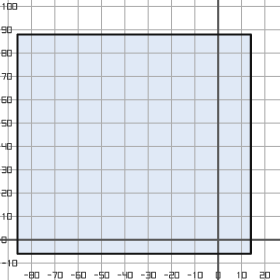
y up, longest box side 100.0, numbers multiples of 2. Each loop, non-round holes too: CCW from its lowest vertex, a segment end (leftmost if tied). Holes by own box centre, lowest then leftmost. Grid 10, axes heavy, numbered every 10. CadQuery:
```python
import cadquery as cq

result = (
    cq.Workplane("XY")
    .moveTo(-86.0, -6.0)
    .lineTo(14.0, -6.0)
    .lineTo(14.0, 88.0)
    .lineTo(-86.0, 88.0)
    .close()
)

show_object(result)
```